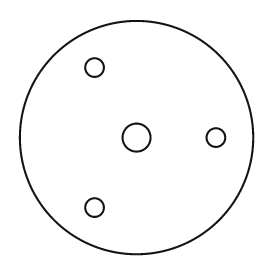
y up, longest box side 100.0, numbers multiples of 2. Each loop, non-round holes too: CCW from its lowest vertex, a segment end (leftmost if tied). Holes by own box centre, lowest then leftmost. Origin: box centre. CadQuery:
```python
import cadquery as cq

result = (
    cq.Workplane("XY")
    .moveTo(0.0, 0.0)
    .circle(50.0)
    .moveTo(-18.0, -30.0)
    .circle(4.0)
    .moveTo(0.0, 0.0)
    .circle(6.0)
    .moveTo(34.0, 0.0)
    .circle(4.0)
    .moveTo(-18.0, 30.0)
    .circle(4.0)
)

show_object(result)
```